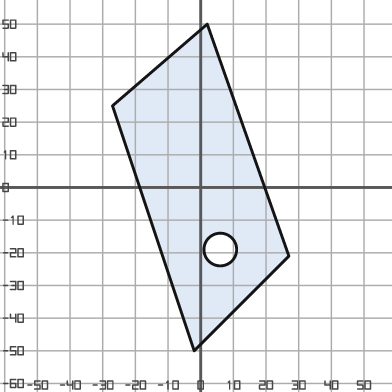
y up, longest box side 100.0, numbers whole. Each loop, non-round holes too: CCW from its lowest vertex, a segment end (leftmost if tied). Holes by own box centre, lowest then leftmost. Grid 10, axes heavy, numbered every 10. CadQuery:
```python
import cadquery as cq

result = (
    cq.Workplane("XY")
    .moveTo(-2.0, -50.0)
    .lineTo(27.0, -21.0)
    .lineTo(2.0, 50.0)
    .lineTo(-27.0, 25.0)
    .close()
    .moveTo(6.0, -19.0)
    .circle(5.0)
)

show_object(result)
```